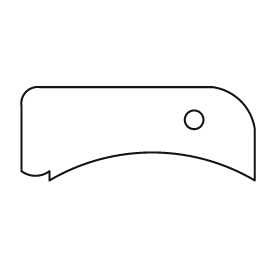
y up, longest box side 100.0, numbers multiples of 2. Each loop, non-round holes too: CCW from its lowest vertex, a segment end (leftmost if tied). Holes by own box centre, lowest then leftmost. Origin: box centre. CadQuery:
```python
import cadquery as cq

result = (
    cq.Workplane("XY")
    .moveTo(-38.0, -20.0)
    .threePointArc((6.0, -8.0), (50.0, -20.0))
    .lineTo(50.0, 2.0)
    .threePointArc((44.0, 14.0), (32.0, 20.0))
    .lineTo(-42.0, 20.0)
    .threePointArc((-48.0, 18.0), (-50.0, 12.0))
    .lineTo(-50.0, -16.0)
    .threePointArc((-44.0, -18.0), (-38.0, -16.0))
    .close()
    .moveTo(24.0, 6.0)
    .circle(4.0)
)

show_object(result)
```